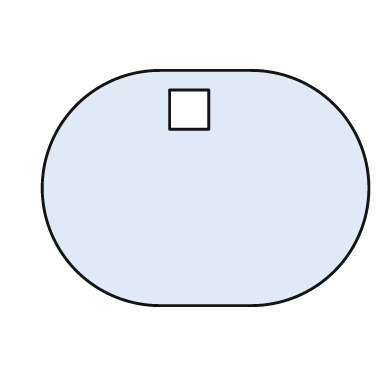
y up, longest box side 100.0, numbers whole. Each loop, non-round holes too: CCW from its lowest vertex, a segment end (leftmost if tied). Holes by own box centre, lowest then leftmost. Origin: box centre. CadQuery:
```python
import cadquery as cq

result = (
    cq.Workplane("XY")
    .moveTo(-14.0, -36.0)
    .lineTo(14.0, -36.0)
    .threePointArc((50.0, 0.0), (14.0, 36.0))
    .lineTo(-14.0, 36.0)
    .threePointArc((-50.0, 0.0), (-14.0, -36.0))
    .close()
    .moveTo(-11.0, 18.0)
    .lineTo(1.0, 18.0)
    .lineTo(1.0, 30.0)
    .lineTo(-11.0, 30.0)
    .close()
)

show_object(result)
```